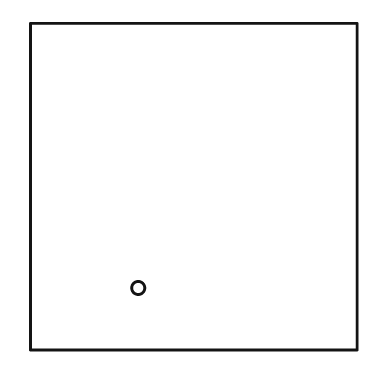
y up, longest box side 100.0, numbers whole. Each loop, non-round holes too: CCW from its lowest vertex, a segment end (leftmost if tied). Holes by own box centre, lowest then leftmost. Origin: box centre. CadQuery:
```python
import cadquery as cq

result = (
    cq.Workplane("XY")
    .moveTo(-50.0, -50.0)
    .lineTo(50.0, -50.0)
    .lineTo(50.0, 50.0)
    .lineTo(-50.0, 50.0)
    .close()
    .moveTo(-17.0, -31.0)
    .circle(2.0)
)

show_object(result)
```